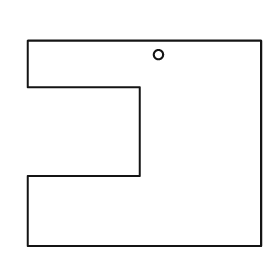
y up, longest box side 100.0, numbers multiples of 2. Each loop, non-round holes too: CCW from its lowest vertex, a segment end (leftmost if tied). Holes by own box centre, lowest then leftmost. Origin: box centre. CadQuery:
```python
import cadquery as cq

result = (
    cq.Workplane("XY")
    .moveTo(-50.0, -44.0)
    .lineTo(50.0, -44.0)
    .lineTo(50.0, 44.0)
    .lineTo(-50.0, 44.0)
    .lineTo(-50.0, 24.0)
    .lineTo(-2.0, 24.0)
    .lineTo(-2.0, -14.0)
    .lineTo(-50.0, -14.0)
    .close()
    .moveTo(6.0, 38.0)
    .circle(2.0)
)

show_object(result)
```